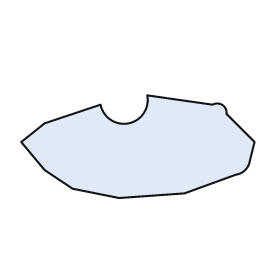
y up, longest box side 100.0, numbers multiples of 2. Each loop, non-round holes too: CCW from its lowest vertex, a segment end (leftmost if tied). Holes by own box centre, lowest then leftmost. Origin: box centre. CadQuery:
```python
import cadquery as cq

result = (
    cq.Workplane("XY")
    .moveTo(-8.0, -22.0)
    .lineTo(20.0, -20.0)
    .lineTo(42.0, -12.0)
    .threePointArc((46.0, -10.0), (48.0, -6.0))
    .lineTo(50.0, 2.0)
    .lineTo(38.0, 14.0)
    .threePointArc((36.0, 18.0), (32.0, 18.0))
    .lineTo(4.0, 22.0)
    .threePointArc((-4.0, 10.0), (-16.0, 18.0))
    .lineTo(-40.0, 10.0)
    .lineTo(-50.0, 2.0)
    .lineTo(-40.0, -10.0)
    .lineTo(-28.0, -18.0)
    .close()
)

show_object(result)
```